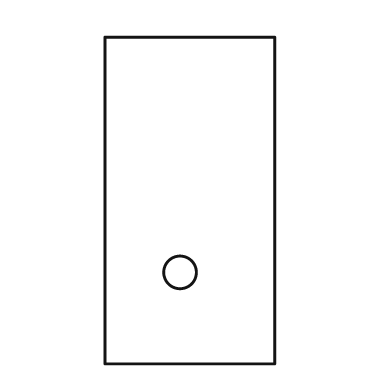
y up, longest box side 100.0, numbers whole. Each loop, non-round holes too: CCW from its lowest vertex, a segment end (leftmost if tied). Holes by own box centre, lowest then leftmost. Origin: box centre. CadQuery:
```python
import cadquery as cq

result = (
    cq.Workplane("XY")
    .moveTo(-26.0, -50.0)
    .lineTo(26.0, -50.0)
    .lineTo(26.0, 50.0)
    .lineTo(-26.0, 50.0)
    .close()
    .moveTo(-3.0, -22.0)
    .circle(5.0)
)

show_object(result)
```